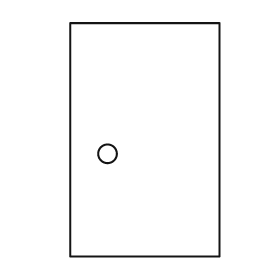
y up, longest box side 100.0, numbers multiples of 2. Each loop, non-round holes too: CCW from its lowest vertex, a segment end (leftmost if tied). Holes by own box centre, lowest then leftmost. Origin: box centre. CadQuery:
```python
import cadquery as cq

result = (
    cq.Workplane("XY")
    .moveTo(-32.0, -50.0)
    .lineTo(32.0, -50.0)
    .lineTo(32.0, 50.0)
    .lineTo(-32.0, 50.0)
    .close()
    .moveTo(-16.0, -6.0)
    .circle(4.0)
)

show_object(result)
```